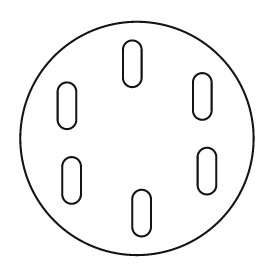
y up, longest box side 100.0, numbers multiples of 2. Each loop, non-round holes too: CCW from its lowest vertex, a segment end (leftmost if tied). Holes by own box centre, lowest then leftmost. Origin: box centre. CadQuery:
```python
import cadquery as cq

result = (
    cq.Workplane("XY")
    .moveTo(0.0, 0.0)
    .circle(50.0)
    .moveTo(-2.0, -38.0)
    .threePointArc((2.0, -42.0), (6.0, -38.0))
    .lineTo(6.0, -26.0)
    .threePointArc((2.0, -22.0), (-2.0, -26.0))
    .close()
    .moveTo(-32.0, -24.0)
    .threePointArc((-28.0, -28.0), (-24.0, -24.0))
    .lineTo(-24.0, -12.0)
    .threePointArc((-28.0, -8.0), (-32.0, -12.0))
    .close()
    .moveTo(26.0, -20.0)
    .threePointArc((30.0, -24.0), (34.0, -20.0))
    .lineTo(34.0, -8.0)
    .threePointArc((30.0, -4.0), (26.0, -8.0))
    .close()
    .moveTo(-34.0, 8.0)
    .threePointArc((-30.0, 4.0), (-26.0, 8.0))
    .lineTo(-26.0, 20.0)
    .threePointArc((-30.0, 24.0), (-34.0, 20.0))
    .close()
    .moveTo(24.0, 12.0)
    .threePointArc((28.0, 8.0), (32.0, 12.0))
    .lineTo(32.0, 24.0)
    .threePointArc((28.0, 28.0), (24.0, 24.0))
    .close()
    .moveTo(-6.0, 26.0)
    .threePointArc((-2.0, 22.0), (2.0, 26.0))
    .lineTo(2.0, 38.0)
    .threePointArc((-2.0, 42.0), (-6.0, 38.0))
    .close()
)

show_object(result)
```